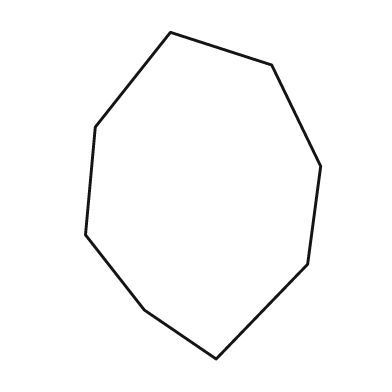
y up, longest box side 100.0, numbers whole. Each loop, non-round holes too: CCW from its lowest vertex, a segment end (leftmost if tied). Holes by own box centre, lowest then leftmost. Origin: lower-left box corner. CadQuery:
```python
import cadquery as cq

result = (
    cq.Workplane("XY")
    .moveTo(40.0, 0.0)
    .lineTo(68.0, 29.0)
    .lineTo(72.0, 59.0)
    .lineTo(57.0, 90.0)
    .lineTo(26.0, 100.0)
    .lineTo(3.0, 71.0)
    .lineTo(0.0, 38.0)
    .lineTo(18.0, 15.0)
    .close()
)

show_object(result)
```